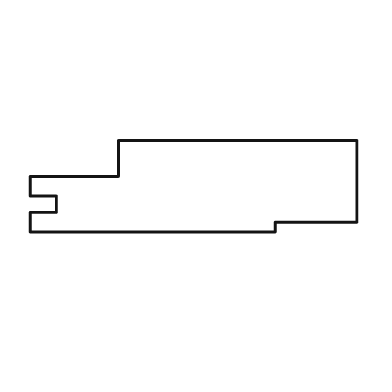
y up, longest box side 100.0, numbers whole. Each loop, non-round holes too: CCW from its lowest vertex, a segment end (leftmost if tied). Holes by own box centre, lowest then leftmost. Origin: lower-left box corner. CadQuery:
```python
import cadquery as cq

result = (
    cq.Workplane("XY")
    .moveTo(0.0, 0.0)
    .lineTo(75.0, 0.0)
    .lineTo(75.0, 3.0)
    .lineTo(100.0, 3.0)
    .lineTo(100.0, 28.0)
    .lineTo(27.0, 28.0)
    .lineTo(27.0, 17.0)
    .lineTo(0.0, 17.0)
    .lineTo(0.0, 11.0)
    .lineTo(8.0, 11.0)
    .lineTo(8.0, 6.0)
    .lineTo(0.0, 6.0)
    .close()
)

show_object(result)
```